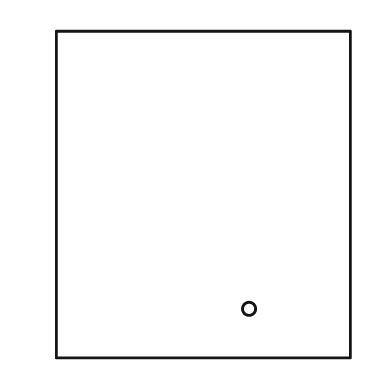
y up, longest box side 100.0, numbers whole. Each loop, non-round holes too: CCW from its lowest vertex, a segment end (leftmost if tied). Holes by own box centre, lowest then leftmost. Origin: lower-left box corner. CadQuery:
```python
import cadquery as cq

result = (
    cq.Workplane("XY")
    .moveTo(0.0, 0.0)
    .lineTo(90.0, 0.0)
    .lineTo(90.0, 100.0)
    .lineTo(0.0, 100.0)
    .close()
    .moveTo(59.0, 15.0)
    .circle(2.0)
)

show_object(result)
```